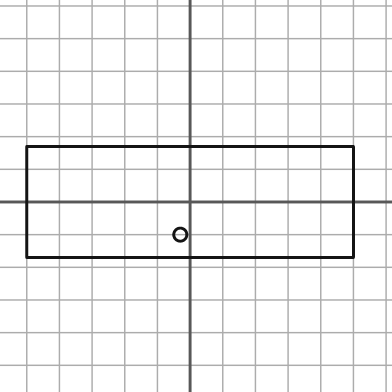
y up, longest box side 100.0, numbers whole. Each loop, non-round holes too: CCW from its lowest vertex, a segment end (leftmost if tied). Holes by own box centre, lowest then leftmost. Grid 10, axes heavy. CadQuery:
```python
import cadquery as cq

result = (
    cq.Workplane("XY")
    .moveTo(-50.0, -17.0)
    .lineTo(50.0, -17.0)
    .lineTo(50.0, 17.0)
    .lineTo(-50.0, 17.0)
    .close()
    .moveTo(-3.0, -10.0)
    .circle(2.0)
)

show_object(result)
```